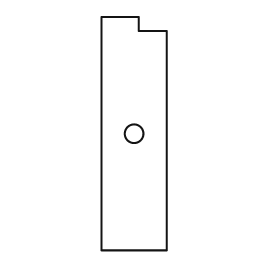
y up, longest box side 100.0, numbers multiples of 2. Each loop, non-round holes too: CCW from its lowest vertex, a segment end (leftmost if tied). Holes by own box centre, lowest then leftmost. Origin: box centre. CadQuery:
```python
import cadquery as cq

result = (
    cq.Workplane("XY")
    .moveTo(-14.0, -50.0)
    .lineTo(14.0, -50.0)
    .lineTo(14.0, 44.0)
    .lineTo(2.0, 44.0)
    .lineTo(2.0, 50.0)
    .lineTo(-14.0, 50.0)
    .close()
    .moveTo(0.0, 0.0)
    .circle(4.0)
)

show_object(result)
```